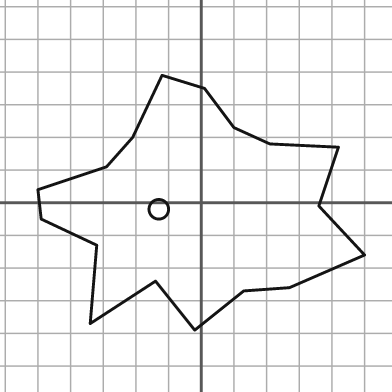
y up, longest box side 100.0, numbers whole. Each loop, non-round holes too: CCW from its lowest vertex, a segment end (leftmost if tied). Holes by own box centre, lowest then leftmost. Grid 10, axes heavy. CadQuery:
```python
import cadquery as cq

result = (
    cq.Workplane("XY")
    .moveTo(-2.0, -39.0)
    .lineTo(13.0, -27.0)
    .lineTo(27.0, -26.0)
    .lineTo(50.0, -16.0)
    .lineTo(36.0, -1.0)
    .lineTo(42.0, 17.0)
    .lineTo(21.0, 18.0)
    .lineTo(10.0, 23.0)
    .lineTo(1.0, 35.0)
    .lineTo(-12.0, 39.0)
    .lineTo(-21.0, 20.0)
    .lineTo(-29.0, 11.0)
    .lineTo(-50.0, 4.0)
    .lineTo(-49.0, -5.0)
    .lineTo(-32.0, -13.0)
    .lineTo(-34.0, -37.0)
    .lineTo(-14.0, -24.0)
    .close()
    .moveTo(-13.0, -2.0)
    .circle(3.0)
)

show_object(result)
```